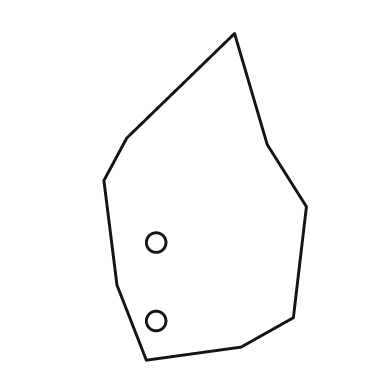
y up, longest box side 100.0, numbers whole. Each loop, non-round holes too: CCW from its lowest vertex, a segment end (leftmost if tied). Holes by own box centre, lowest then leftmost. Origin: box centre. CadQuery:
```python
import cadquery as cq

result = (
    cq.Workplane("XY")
    .moveTo(-18.0, -50.0)
    .lineTo(11.0, -46.0)
    .lineTo(27.0, -37.0)
    .lineTo(31.0, -3.0)
    .lineTo(19.0, 16.0)
    .lineTo(9.0, 50.0)
    .lineTo(-24.0, 18.0)
    .lineTo(-31.0, 5.0)
    .lineTo(-27.0, -27.0)
    .close()
    .moveTo(-15.0, -38.0)
    .circle(3.0)
    .moveTo(-15.0, -14.0)
    .circle(3.0)
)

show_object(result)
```